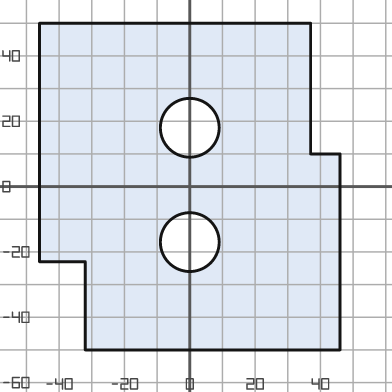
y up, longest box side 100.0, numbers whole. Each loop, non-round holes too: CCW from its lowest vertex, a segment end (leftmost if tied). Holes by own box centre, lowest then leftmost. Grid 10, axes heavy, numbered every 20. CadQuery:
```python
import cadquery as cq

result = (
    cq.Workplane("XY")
    .moveTo(-32.0, -50.0)
    .lineTo(46.0, -50.0)
    .lineTo(46.0, 10.0)
    .lineTo(37.0, 10.0)
    .lineTo(37.0, 50.0)
    .lineTo(-46.0, 50.0)
    .lineTo(-46.0, -23.0)
    .lineTo(-32.0, -23.0)
    .close()
    .moveTo(0.0, -17.0)
    .circle(9.0)
    .moveTo(0.0, 18.0)
    .circle(9.0)
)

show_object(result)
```